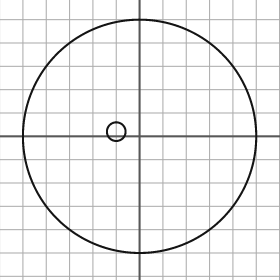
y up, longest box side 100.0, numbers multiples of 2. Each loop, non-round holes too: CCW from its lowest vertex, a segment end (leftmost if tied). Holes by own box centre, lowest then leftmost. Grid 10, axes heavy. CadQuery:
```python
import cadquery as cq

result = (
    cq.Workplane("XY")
    .moveTo(0.0, 0.0)
    .circle(50.0)
    .moveTo(-10.0, 2.0)
    .circle(4.0)
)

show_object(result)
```